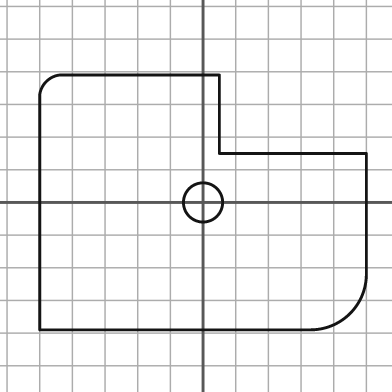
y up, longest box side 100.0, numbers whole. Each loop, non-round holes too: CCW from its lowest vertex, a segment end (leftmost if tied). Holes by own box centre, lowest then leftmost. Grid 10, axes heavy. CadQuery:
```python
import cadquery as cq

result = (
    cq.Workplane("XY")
    .moveTo(-50.0, -39.0)
    .lineTo(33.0, -39.0)
    .threePointArc((45.0, -34.0), (50.0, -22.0))
    .lineTo(50.0, 15.0)
    .lineTo(5.0, 15.0)
    .lineTo(5.0, 39.0)
    .lineTo(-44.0, 39.0)
    .threePointArc((-48.0, 37.0), (-50.0, 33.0))
    .close()
    .moveTo(0.0, 0.0)
    .circle(6.0)
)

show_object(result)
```